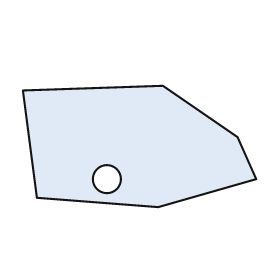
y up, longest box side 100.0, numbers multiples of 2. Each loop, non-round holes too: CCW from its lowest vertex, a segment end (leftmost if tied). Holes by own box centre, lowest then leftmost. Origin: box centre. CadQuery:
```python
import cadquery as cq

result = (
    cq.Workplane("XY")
    .moveTo(8.0, -26.0)
    .lineTo(50.0, -14.0)
    .lineTo(42.0, 4.0)
    .lineTo(10.0, 26.0)
    .lineTo(-50.0, 24.0)
    .lineTo(-44.0, -22.0)
    .close()
    .moveTo(-14.0, -14.0)
    .circle(6.0)
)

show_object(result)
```